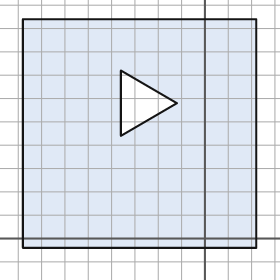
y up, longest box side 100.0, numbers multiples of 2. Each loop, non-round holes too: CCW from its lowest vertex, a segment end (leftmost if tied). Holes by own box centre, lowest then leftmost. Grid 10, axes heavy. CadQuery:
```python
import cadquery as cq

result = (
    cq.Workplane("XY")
    .moveTo(-78.0, -4.0)
    .lineTo(22.0, -4.0)
    .lineTo(22.0, 94.0)
    .lineTo(-78.0, 94.0)
    .close()
    .moveTo(-36.0, 44.0)
    .lineTo(-12.0, 58.0)
    .lineTo(-36.0, 72.0)
    .close()
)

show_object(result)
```